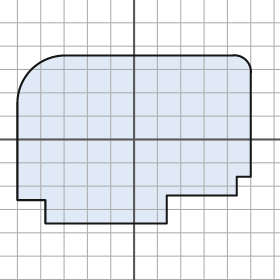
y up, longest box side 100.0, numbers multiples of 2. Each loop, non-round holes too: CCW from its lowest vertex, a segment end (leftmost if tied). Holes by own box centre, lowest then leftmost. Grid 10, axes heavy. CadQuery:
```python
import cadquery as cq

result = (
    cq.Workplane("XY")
    .moveTo(-38.0, -36.0)
    .lineTo(14.0, -36.0)
    .lineTo(14.0, -24.0)
    .lineTo(44.0, -24.0)
    .lineTo(44.0, -16.0)
    .lineTo(50.0, -16.0)
    .lineTo(50.0, 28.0)
    .threePointArc((48.0, 34.0), (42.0, 36.0))
    .lineTo(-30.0, 36.0)
    .threePointArc((-44.0, 30.0), (-50.0, 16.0))
    .lineTo(-50.0, -26.0)
    .lineTo(-38.0, -26.0)
    .close()
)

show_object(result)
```